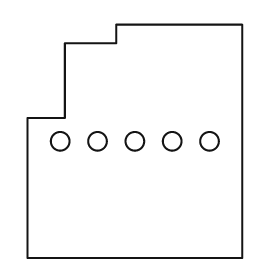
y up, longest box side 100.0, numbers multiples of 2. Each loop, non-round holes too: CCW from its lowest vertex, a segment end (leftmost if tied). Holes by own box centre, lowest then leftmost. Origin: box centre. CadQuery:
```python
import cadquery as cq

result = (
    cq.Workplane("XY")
    .moveTo(-46.0, -50.0)
    .lineTo(46.0, -50.0)
    .lineTo(46.0, 50.0)
    .lineTo(-8.0, 50.0)
    .lineTo(-8.0, 42.0)
    .lineTo(-30.0, 42.0)
    .lineTo(-30.0, 10.0)
    .lineTo(-46.0, 10.0)
    .close()
    .moveTo(-32.0, 0.0)
    .circle(4.0)
    .moveTo(-16.0, 0.0)
    .circle(4.0)
    .moveTo(0.0, 0.0)
    .circle(4.0)
    .moveTo(16.0, 0.0)
    .circle(4.0)
    .moveTo(32.0, 0.0)
    .circle(4.0)
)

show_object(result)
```